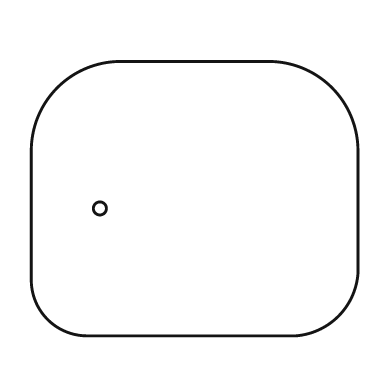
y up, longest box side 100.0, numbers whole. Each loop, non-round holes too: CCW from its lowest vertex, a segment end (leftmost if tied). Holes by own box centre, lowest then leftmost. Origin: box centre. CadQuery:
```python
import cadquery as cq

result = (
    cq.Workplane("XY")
    .moveTo(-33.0, -42.0)
    .lineTo(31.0, -42.0)
    .threePointArc((44.0, -36.0), (50.0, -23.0))
    .lineTo(50.0, 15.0)
    .threePointArc((42.0, 34.0), (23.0, 42.0))
    .lineTo(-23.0, 42.0)
    .threePointArc((-42.0, 34.0), (-50.0, 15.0))
    .lineTo(-50.0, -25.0)
    .threePointArc((-45.0, -37.0), (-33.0, -42.0))
    .close()
    .moveTo(-29.0, -3.0)
    .circle(2.0)
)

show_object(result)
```